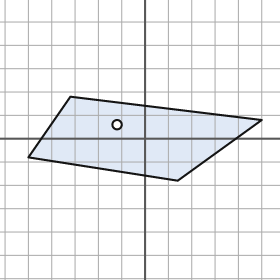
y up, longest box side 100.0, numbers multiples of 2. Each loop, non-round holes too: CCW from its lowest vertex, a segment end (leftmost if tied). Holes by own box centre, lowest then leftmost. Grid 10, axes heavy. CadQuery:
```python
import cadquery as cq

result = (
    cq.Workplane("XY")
    .moveTo(14.0, -18.0)
    .lineTo(50.0, 8.0)
    .lineTo(-32.0, 18.0)
    .lineTo(-50.0, -8.0)
    .close()
    .moveTo(-12.0, 6.0)
    .circle(2.0)
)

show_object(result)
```